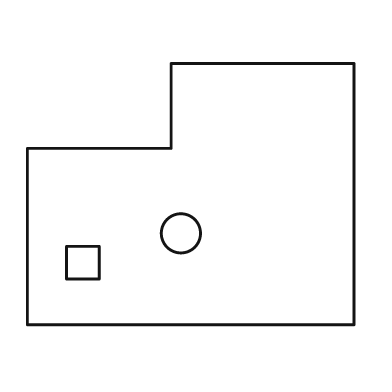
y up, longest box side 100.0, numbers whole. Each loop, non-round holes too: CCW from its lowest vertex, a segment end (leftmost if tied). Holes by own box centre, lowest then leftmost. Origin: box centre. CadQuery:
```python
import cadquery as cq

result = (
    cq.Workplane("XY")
    .moveTo(-50.0, -40.0)
    .lineTo(50.0, -40.0)
    .lineTo(50.0, 40.0)
    .lineTo(-6.0, 40.0)
    .lineTo(-6.0, 14.0)
    .lineTo(-50.0, 14.0)
    .close()
    .moveTo(-38.0, -26.0)
    .lineTo(-28.0, -26.0)
    .lineTo(-28.0, -16.0)
    .lineTo(-38.0, -16.0)
    .close()
    .moveTo(-3.0, -12.0)
    .circle(6.0)
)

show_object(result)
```